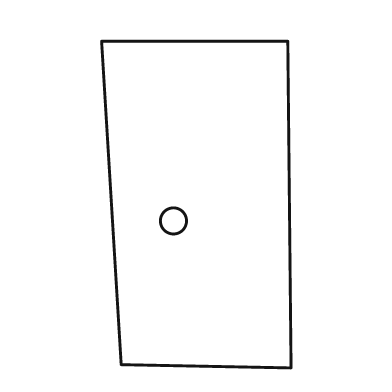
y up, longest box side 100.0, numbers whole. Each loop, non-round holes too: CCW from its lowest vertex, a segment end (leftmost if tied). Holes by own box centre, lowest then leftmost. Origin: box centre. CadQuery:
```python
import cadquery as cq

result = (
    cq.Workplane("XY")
    .moveTo(29.0, -50.0)
    .lineTo(28.0, 50.0)
    .lineTo(-29.0, 50.0)
    .lineTo(-23.0, -49.0)
    .close()
    .moveTo(-7.0, -5.0)
    .circle(4.0)
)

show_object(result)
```